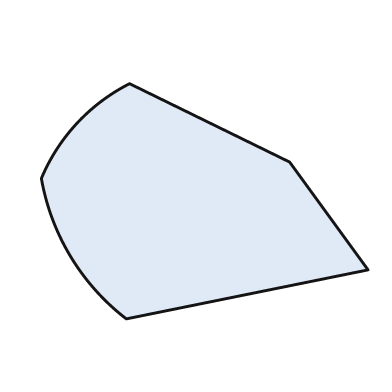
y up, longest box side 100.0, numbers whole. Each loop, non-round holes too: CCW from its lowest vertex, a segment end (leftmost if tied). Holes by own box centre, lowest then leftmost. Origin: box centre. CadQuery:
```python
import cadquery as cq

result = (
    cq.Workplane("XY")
    .moveTo(-24.0, -36.0)
    .lineTo(50.0, -21.0)
    .lineTo(26.0, 12.0)
    .lineTo(-23.0, 36.0)
    .threePointArc((-39.0, 24.0), (-50.0, 7.0))
    .threePointArc((-41.0, -17.0), (-24.0, -36.0))
    .close()
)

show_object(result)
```